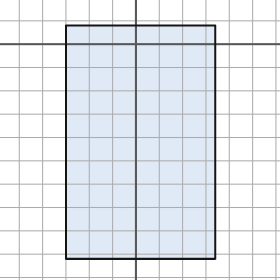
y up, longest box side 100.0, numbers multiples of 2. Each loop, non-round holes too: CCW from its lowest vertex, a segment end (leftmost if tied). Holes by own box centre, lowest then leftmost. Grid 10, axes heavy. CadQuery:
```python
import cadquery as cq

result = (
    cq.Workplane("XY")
    .moveTo(-30.0, -92.0)
    .lineTo(34.0, -92.0)
    .lineTo(34.0, 8.0)
    .lineTo(-30.0, 8.0)
    .close()
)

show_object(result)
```